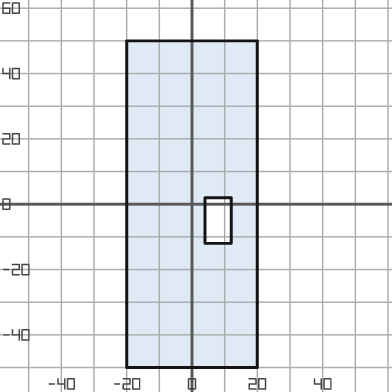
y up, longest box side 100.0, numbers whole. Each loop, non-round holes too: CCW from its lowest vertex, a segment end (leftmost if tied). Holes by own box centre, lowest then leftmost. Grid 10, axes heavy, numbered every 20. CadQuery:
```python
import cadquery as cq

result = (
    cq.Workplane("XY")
    .moveTo(-20.0, -50.0)
    .lineTo(20.0, -50.0)
    .lineTo(20.0, 50.0)
    .lineTo(-20.0, 50.0)
    .close()
    .moveTo(4.0, -12.0)
    .lineTo(12.0, -12.0)
    .lineTo(12.0, 2.0)
    .lineTo(4.0, 2.0)
    .close()
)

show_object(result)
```